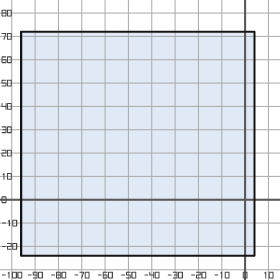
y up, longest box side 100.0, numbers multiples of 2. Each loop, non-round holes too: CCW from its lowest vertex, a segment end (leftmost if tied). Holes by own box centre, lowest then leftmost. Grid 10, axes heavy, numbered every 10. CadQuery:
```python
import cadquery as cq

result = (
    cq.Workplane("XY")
    .moveTo(-96.0, -24.0)
    .lineTo(4.0, -24.0)
    .lineTo(4.0, 72.0)
    .lineTo(-96.0, 72.0)
    .close()
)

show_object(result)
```